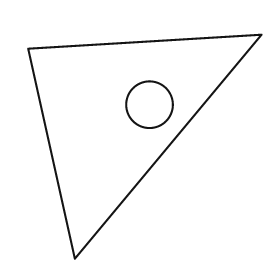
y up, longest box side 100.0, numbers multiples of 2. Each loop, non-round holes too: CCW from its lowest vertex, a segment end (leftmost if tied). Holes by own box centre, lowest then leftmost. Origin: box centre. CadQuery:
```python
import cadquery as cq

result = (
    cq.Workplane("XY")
    .moveTo(-30.0, -48.0)
    .lineTo(50.0, 48.0)
    .lineTo(-50.0, 42.0)
    .close()
    .moveTo(2.0, 18.0)
    .circle(10.0)
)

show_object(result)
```